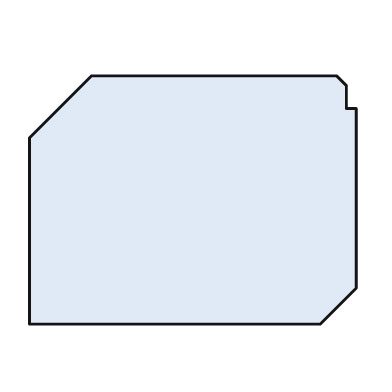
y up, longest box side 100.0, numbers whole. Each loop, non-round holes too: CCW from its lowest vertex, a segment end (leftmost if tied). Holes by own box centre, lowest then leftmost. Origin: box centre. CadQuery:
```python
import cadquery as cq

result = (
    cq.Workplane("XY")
    .moveTo(-50.0, -38.0)
    .lineTo(39.0, -38.0)
    .lineTo(50.0, -27.0)
    .lineTo(50.0, 28.0)
    .lineTo(47.0, 28.0)
    .lineTo(47.0, 35.0)
    .lineTo(44.0, 38.0)
    .lineTo(-31.0, 38.0)
    .lineTo(-50.0, 19.0)
    .close()
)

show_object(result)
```